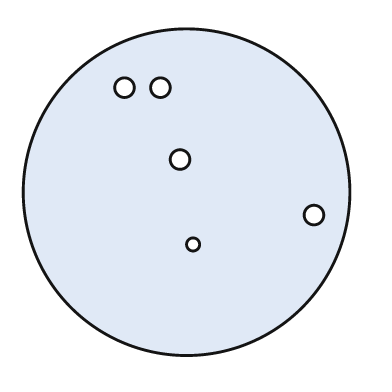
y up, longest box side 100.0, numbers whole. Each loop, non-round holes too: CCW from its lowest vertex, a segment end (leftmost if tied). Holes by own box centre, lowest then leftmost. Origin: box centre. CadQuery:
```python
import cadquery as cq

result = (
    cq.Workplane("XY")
    .moveTo(0.0, 0.0)
    .circle(50.0)
    .moveTo(2.0, -16.0)
    .circle(2.0)
    .moveTo(39.0, -7.0)
    .circle(3.0)
    .moveTo(-2.0, 10.0)
    .circle(3.0)
    .moveTo(-19.0, 32.0)
    .circle(3.0)
    .moveTo(-8.0, 32.0)
    .circle(3.0)
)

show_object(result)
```